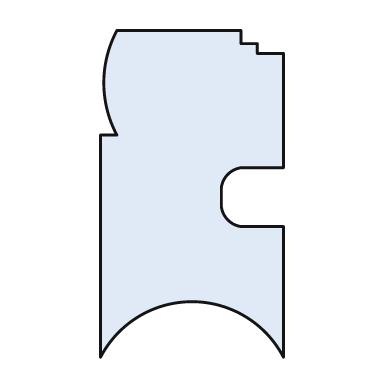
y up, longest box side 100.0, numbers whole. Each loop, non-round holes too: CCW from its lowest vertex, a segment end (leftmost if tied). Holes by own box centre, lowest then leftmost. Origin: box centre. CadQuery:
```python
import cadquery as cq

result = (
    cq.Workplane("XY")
    .moveTo(-28.0, -50.0)
    .threePointArc((0.0, -33.0), (28.0, -50.0))
    .lineTo(28.0, -10.0)
    .lineTo(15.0, -10.0)
    .threePointArc((11.0, -8.0), (9.0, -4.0))
    .lineTo(9.0, 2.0)
    .threePointArc((11.0, 6.0), (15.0, 8.0))
    .lineTo(28.0, 8.0)
    .lineTo(28.0, 43.0)
    .lineTo(20.0, 43.0)
    .lineTo(20.0, 46.0)
    .lineTo(15.0, 46.0)
    .lineTo(15.0, 50.0)
    .lineTo(-23.0, 50.0)
    .threePointArc((-27.0, 34.0), (-23.0, 18.0))
    .lineTo(-28.0, 18.0)
    .close()
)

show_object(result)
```